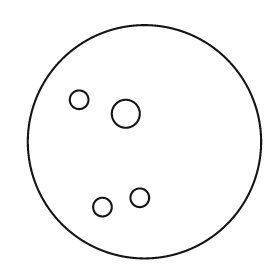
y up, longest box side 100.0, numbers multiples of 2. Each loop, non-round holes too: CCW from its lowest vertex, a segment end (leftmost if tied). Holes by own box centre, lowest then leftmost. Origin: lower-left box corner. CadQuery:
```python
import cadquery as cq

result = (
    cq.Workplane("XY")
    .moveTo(50.0, 50.0)
    .circle(50.0)
    .moveTo(32.0, 22.0)
    .circle(4.0)
    .moveTo(48.0, 26.0)
    .circle(4.0)
    .moveTo(42.0, 62.0)
    .circle(6.0)
    .moveTo(22.0, 68.0)
    .circle(4.0)
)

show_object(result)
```